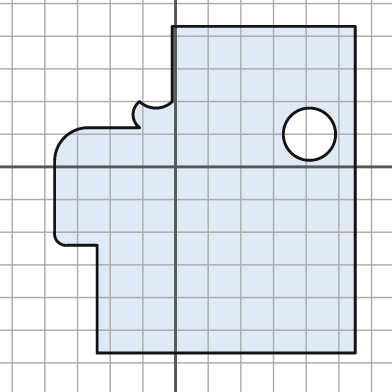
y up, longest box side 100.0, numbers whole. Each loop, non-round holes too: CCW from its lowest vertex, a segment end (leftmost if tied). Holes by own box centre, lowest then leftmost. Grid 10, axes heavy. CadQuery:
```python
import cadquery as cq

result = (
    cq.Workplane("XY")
    .moveTo(-24.0, -57.0)
    .lineTo(55.0, -57.0)
    .lineTo(55.0, 43.0)
    .lineTo(-1.0, 43.0)
    .lineTo(-1.0, 20.0)
    .threePointArc((-6.0, 18.0), (-11.0, 20.0))
    .threePointArc((-13.0, 16.0), (-11.0, 12.0))
    .lineTo(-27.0, 12.0)
    .threePointArc((-34.0, 9.0), (-37.0, 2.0))
    .lineTo(-37.0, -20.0)
    .threePointArc((-36.0, -23.0), (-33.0, -24.0))
    .lineTo(-24.0, -24.0)
    .close()
    .moveTo(41.0, 10.0)
    .circle(8.0)
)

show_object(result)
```